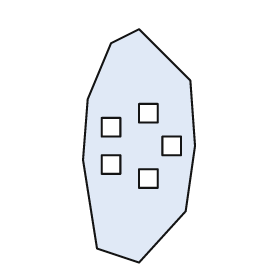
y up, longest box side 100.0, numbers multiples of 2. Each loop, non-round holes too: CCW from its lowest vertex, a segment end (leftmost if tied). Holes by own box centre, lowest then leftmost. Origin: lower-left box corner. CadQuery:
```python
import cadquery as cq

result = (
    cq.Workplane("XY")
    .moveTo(24.0, 0.0)
    .lineTo(44.0, 22.0)
    .lineTo(48.0, 50.0)
    .lineTo(46.0, 78.0)
    .lineTo(24.0, 100.0)
    .lineTo(12.0, 94.0)
    .lineTo(2.0, 70.0)
    .lineTo(0.0, 44.0)
    .lineTo(6.0, 6.0)
    .close()
    .moveTo(24.0, 32.0)
    .lineTo(32.0, 32.0)
    .lineTo(32.0, 40.0)
    .lineTo(24.0, 40.0)
    .close()
    .moveTo(8.0, 38.0)
    .lineTo(16.0, 38.0)
    .lineTo(16.0, 46.0)
    .lineTo(8.0, 46.0)
    .close()
    .moveTo(34.0, 46.0)
    .lineTo(42.0, 46.0)
    .lineTo(42.0, 54.0)
    .lineTo(34.0, 54.0)
    .close()
    .moveTo(8.0, 54.0)
    .lineTo(16.0, 54.0)
    .lineTo(16.0, 62.0)
    .lineTo(8.0, 62.0)
    .close()
    .moveTo(24.0, 60.0)
    .lineTo(32.0, 60.0)
    .lineTo(32.0, 68.0)
    .lineTo(24.0, 68.0)
    .close()
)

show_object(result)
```